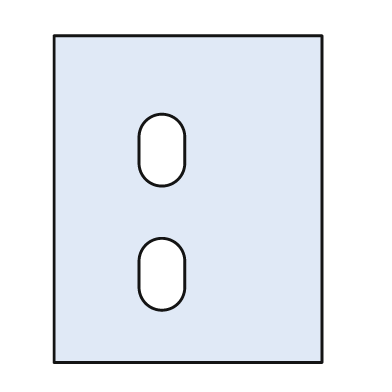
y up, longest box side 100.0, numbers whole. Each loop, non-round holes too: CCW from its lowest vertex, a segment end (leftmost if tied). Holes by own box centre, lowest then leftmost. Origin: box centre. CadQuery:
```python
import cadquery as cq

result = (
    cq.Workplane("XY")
    .moveTo(-41.0, -50.0)
    .lineTo(41.0, -50.0)
    .lineTo(41.0, 50.0)
    .lineTo(-41.0, 50.0)
    .close()
    .moveTo(-15.0, -27.0)
    .threePointArc((-8.0, -34.0), (-1.0, -27.0))
    .lineTo(-1.0, -19.0)
    .threePointArc((-8.0, -12.0), (-15.0, -19.0))
    .close()
    .moveTo(-15.0, 11.0)
    .threePointArc((-8.0, 4.0), (-1.0, 11.0))
    .lineTo(-1.0, 19.0)
    .threePointArc((-8.0, 26.0), (-15.0, 19.0))
    .close()
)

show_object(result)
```